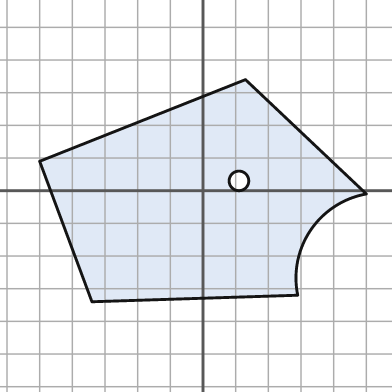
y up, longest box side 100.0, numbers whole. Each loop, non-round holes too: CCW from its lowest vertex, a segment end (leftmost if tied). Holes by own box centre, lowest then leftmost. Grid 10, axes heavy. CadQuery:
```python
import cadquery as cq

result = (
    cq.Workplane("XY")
    .moveTo(-34.0, -34.0)
    .lineTo(29.0, -32.0)
    .threePointArc((33.0, -12.0), (50.0, -1.0))
    .lineTo(13.0, 34.0)
    .lineTo(-50.0, 9.0)
    .close()
    .moveTo(11.0, 3.0)
    .circle(3.0)
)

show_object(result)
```